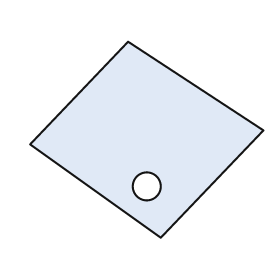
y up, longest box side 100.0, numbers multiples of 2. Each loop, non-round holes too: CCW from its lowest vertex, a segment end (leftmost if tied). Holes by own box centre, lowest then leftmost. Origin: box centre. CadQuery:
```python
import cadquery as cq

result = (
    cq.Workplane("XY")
    .moveTo(6.0, -42.0)
    .lineTo(50.0, 4.0)
    .lineTo(-8.0, 42.0)
    .lineTo(-50.0, -2.0)
    .close()
    .moveTo(0.0, -20.0)
    .circle(6.0)
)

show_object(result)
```